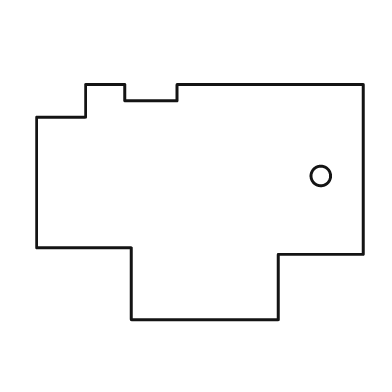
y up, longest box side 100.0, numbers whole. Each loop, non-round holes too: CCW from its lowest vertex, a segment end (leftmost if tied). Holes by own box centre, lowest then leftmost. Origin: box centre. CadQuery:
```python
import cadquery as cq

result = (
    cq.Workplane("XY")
    .moveTo(-21.0, -36.0)
    .lineTo(24.0, -36.0)
    .lineTo(24.0, -16.0)
    .lineTo(50.0, -16.0)
    .lineTo(50.0, 36.0)
    .lineTo(-7.0, 36.0)
    .lineTo(-7.0, 31.0)
    .lineTo(-23.0, 31.0)
    .lineTo(-23.0, 36.0)
    .lineTo(-35.0, 36.0)
    .lineTo(-35.0, 26.0)
    .lineTo(-50.0, 26.0)
    .lineTo(-50.0, -14.0)
    .lineTo(-21.0, -14.0)
    .close()
    .moveTo(37.0, 8.0)
    .circle(3.0)
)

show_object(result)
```